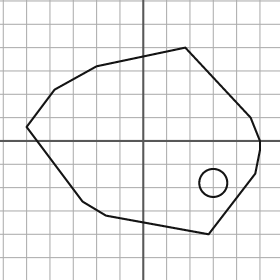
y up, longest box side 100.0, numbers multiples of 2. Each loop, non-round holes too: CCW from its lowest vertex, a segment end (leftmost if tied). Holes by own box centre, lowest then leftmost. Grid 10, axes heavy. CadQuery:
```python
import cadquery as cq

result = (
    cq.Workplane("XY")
    .moveTo(28.0, -40.0)
    .lineTo(48.0, -14.0)
    .lineTo(50.0, -4.0)
    .lineTo(50.0, 0.0)
    .lineTo(46.0, 10.0)
    .lineTo(18.0, 40.0)
    .lineTo(-20.0, 32.0)
    .lineTo(-38.0, 22.0)
    .lineTo(-50.0, 6.0)
    .lineTo(-26.0, -26.0)
    .lineTo(-16.0, -32.0)
    .close()
    .moveTo(30.0, -18.0)
    .circle(6.0)
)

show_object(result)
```